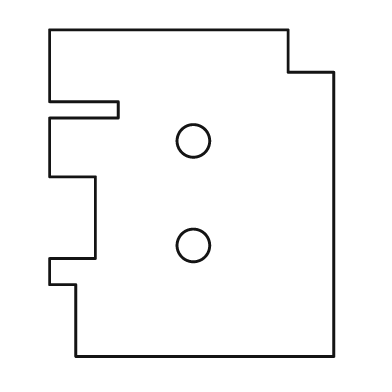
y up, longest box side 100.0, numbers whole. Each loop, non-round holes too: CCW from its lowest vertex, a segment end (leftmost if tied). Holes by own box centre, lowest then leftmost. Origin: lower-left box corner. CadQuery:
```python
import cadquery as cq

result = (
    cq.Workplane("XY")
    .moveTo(8.0, 0.0)
    .lineTo(87.0, 0.0)
    .lineTo(87.0, 87.0)
    .lineTo(73.0, 87.0)
    .lineTo(73.0, 100.0)
    .lineTo(0.0, 100.0)
    .lineTo(0.0, 78.0)
    .lineTo(21.0, 78.0)
    .lineTo(21.0, 73.0)
    .lineTo(0.0, 73.0)
    .lineTo(0.0, 55.0)
    .lineTo(14.0, 55.0)
    .lineTo(14.0, 30.0)
    .lineTo(0.0, 30.0)
    .lineTo(0.0, 22.0)
    .lineTo(8.0, 22.0)
    .close()
    .moveTo(44.0, 34.0)
    .circle(5.0)
    .moveTo(44.0, 66.0)
    .circle(5.0)
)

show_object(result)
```